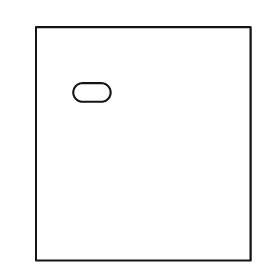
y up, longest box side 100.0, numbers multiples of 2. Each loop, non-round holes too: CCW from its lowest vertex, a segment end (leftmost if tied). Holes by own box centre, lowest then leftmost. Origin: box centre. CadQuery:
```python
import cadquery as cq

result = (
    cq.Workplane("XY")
    .moveTo(-46.0, -50.0)
    .lineTo(46.0, -50.0)
    .lineTo(46.0, 50.0)
    .lineTo(-46.0, 50.0)
    .close()
    .moveTo(-26.0, 18.0)
    .lineTo(-18.0, 18.0)
    .threePointArc((-14.0, 22.0), (-18.0, 26.0))
    .lineTo(-26.0, 26.0)
    .threePointArc((-30.0, 22.0), (-26.0, 18.0))
    .close()
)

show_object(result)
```